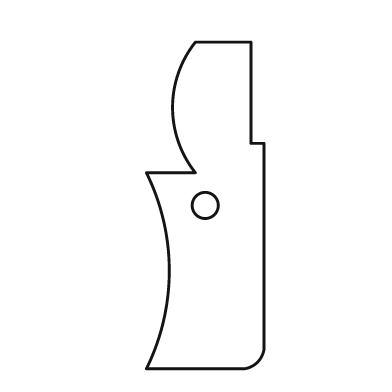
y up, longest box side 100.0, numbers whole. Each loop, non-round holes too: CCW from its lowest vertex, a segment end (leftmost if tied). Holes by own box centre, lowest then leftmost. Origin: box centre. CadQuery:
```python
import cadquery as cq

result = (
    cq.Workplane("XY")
    .moveTo(-18.0, -50.0)
    .lineTo(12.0, -50.0)
    .threePointArc((16.0, -48.0), (18.0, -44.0))
    .lineTo(18.0, 19.0)
    .lineTo(14.0, 19.0)
    .lineTo(14.0, 50.0)
    .lineTo(-3.0, 50.0)
    .threePointArc((-10.0, 30.0), (-3.0, 10.0))
    .lineTo(-18.0, 10.0)
    .threePointArc((-11.0, -20.0), (-18.0, -50.0))
    .close()
    .moveTo(0.0, 0.0)
    .circle(4.0)
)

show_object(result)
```